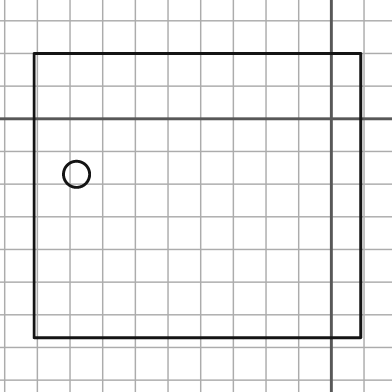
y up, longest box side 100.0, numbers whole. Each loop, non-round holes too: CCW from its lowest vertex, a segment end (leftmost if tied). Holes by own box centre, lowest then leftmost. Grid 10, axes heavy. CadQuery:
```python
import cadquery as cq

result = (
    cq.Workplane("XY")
    .moveTo(-91.0, -67.0)
    .lineTo(9.0, -67.0)
    .lineTo(9.0, 20.0)
    .lineTo(-91.0, 20.0)
    .close()
    .moveTo(-78.0, -17.0)
    .circle(4.0)
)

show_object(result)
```